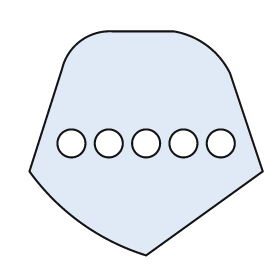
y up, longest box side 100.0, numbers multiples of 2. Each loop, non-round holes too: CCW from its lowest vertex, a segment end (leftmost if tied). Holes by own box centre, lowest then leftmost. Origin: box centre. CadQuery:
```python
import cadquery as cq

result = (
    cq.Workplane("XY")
    .moveTo(0.0, -48.0)
    .lineTo(50.0, -12.0)
    .lineTo(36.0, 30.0)
    .threePointArc((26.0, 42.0), (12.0, 48.0))
    .lineTo(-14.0, 48.0)
    .threePointArc((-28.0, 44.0), (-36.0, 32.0))
    .lineTo(-50.0, -12.0)
    .threePointArc((-28.0, -34.0), (0.0, -48.0))
    .close()
    .moveTo(-32.0, 0.0)
    .circle(6.0)
    .moveTo(-16.0, 0.0)
    .circle(6.0)
    .moveTo(0.0, 0.0)
    .circle(6.0)
    .moveTo(16.0, 0.0)
    .circle(6.0)
    .moveTo(32.0, 0.0)
    .circle(6.0)
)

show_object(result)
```